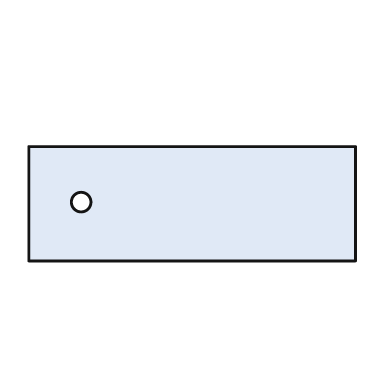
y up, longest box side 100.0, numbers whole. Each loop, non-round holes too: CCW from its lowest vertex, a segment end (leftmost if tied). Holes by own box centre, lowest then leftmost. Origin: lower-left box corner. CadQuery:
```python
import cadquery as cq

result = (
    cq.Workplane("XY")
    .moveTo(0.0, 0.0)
    .lineTo(100.0, 0.0)
    .lineTo(100.0, 35.0)
    .lineTo(0.0, 35.0)
    .close()
    .moveTo(16.0, 18.0)
    .circle(3.0)
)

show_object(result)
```